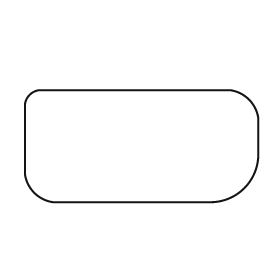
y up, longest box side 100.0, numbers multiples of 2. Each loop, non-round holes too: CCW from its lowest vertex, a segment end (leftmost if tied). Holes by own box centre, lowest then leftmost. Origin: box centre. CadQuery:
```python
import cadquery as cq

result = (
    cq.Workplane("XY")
    .moveTo(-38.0, -24.0)
    .lineTo(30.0, -24.0)
    .threePointArc((44.0, -18.0), (50.0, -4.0))
    .lineTo(50.0, 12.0)
    .threePointArc((46.0, 20.0), (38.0, 24.0))
    .lineTo(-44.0, 24.0)
    .threePointArc((-48.0, 22.0), (-50.0, 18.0))
    .lineTo(-50.0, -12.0)
    .threePointArc((-46.0, -20.0), (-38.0, -24.0))
    .close()
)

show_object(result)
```